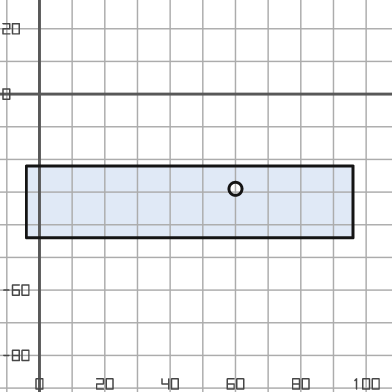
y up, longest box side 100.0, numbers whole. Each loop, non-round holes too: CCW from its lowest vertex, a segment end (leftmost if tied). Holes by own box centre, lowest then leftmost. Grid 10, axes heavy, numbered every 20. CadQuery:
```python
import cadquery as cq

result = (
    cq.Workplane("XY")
    .moveTo(-4.0, -44.0)
    .lineTo(96.0, -44.0)
    .lineTo(96.0, -22.0)
    .lineTo(-4.0, -22.0)
    .close()
    .moveTo(60.0, -29.0)
    .circle(2.0)
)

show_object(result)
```